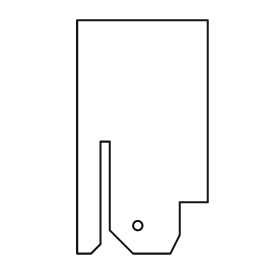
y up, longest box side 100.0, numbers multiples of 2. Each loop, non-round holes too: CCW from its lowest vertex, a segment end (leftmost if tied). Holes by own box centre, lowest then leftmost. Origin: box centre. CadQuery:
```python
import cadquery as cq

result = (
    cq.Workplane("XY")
    .moveTo(-28.0, -50.0)
    .lineTo(-22.0, -50.0)
    .lineTo(-18.0, -46.0)
    .lineTo(-18.0, -2.0)
    .lineTo(-14.0, -2.0)
    .lineTo(-14.0, -40.0)
    .lineTo(-4.0, -50.0)
    .lineTo(12.0, -50.0)
    .lineTo(16.0, -42.0)
    .lineTo(16.0, -28.0)
    .lineTo(28.0, -28.0)
    .lineTo(28.0, 50.0)
    .lineTo(-28.0, 50.0)
    .close()
    .moveTo(-2.0, -38.0)
    .circle(2.0)
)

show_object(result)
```